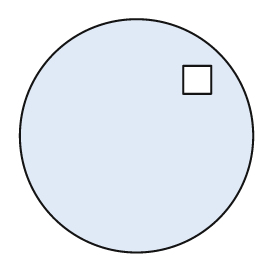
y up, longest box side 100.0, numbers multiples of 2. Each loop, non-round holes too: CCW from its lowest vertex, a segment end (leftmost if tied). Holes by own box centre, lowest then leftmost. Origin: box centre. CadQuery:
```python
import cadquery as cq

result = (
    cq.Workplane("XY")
    .moveTo(0.0, 0.0)
    .circle(50.0)
    .moveTo(20.0, 18.0)
    .lineTo(32.0, 18.0)
    .lineTo(32.0, 30.0)
    .lineTo(20.0, 30.0)
    .close()
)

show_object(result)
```